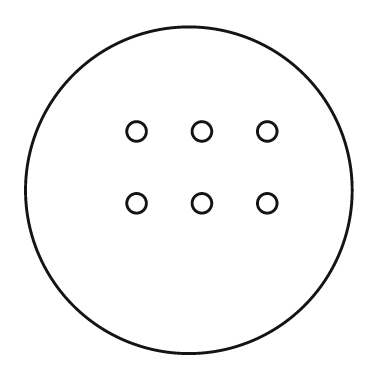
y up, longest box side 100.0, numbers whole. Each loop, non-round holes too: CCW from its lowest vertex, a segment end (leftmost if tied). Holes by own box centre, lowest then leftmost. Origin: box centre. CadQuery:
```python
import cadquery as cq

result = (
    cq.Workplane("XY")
    .moveTo(0.0, 0.0)
    .circle(50.0)
    .moveTo(-16.0, -4.0)
    .circle(3.0)
    .moveTo(4.0, -4.0)
    .circle(3.0)
    .moveTo(24.0, -4.0)
    .circle(3.0)
    .moveTo(-16.0, 18.0)
    .circle(3.0)
    .moveTo(4.0, 18.0)
    .circle(3.0)
    .moveTo(24.0, 18.0)
    .circle(3.0)
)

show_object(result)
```